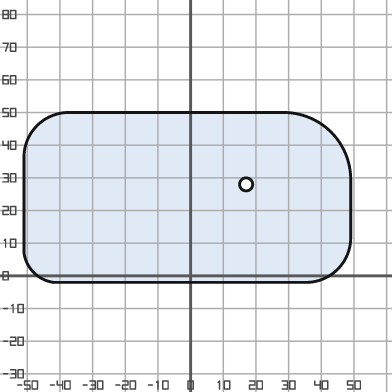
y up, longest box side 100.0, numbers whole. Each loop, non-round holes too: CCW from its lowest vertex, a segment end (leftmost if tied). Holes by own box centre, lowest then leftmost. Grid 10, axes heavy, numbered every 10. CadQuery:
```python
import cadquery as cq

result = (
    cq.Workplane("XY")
    .moveTo(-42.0, -2.0)
    .lineTo(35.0, -2.0)
    .threePointArc((45.0, 2.0), (49.0, 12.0))
    .lineTo(49.0, 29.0)
    .threePointArc((43.0, 44.0), (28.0, 50.0))
    .lineTo(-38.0, 50.0)
    .threePointArc((-47.0, 46.0), (-51.0, 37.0))
    .lineTo(-51.0, 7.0)
    .threePointArc((-48.0, 1.0), (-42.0, -2.0))
    .close()
    .moveTo(17.0, 28.0)
    .circle(2.0)
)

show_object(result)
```